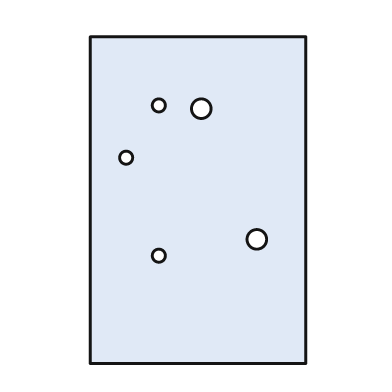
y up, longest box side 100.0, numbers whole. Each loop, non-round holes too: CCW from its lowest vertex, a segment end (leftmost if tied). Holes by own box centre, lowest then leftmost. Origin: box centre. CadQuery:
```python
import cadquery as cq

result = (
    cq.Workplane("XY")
    .moveTo(-33.0, -50.0)
    .lineTo(33.0, -50.0)
    .lineTo(33.0, 50.0)
    .lineTo(-33.0, 50.0)
    .close()
    .moveTo(-12.0, -17.0)
    .circle(2.0)
    .moveTo(18.0, -12.0)
    .circle(3.0)
    .moveTo(-22.0, 13.0)
    .circle(2.0)
    .moveTo(1.0, 28.0)
    .circle(3.0)
    .moveTo(-12.0, 29.0)
    .circle(2.0)
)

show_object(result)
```